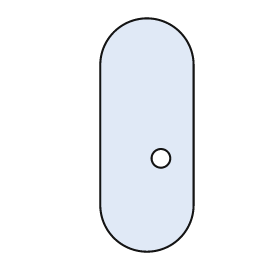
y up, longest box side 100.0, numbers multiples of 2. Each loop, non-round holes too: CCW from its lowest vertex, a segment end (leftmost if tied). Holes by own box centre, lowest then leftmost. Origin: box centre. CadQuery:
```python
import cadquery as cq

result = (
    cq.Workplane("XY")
    .moveTo(-20.0, -30.0)
    .threePointArc((0.0, -50.0), (20.0, -30.0))
    .lineTo(20.0, 30.0)
    .threePointArc((0.0, 50.0), (-20.0, 30.0))
    .close()
    .moveTo(6.0, -10.0)
    .circle(4.0)
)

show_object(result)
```